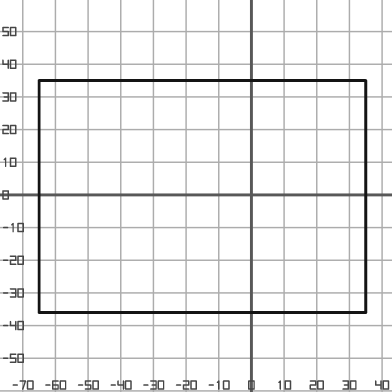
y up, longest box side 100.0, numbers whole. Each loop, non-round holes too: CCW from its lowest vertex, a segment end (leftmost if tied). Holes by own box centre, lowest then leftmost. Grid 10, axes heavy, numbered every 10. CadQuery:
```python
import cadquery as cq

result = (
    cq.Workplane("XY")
    .moveTo(-65.0, -36.0)
    .lineTo(35.0, -36.0)
    .lineTo(35.0, 35.0)
    .lineTo(-65.0, 35.0)
    .close()
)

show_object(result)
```